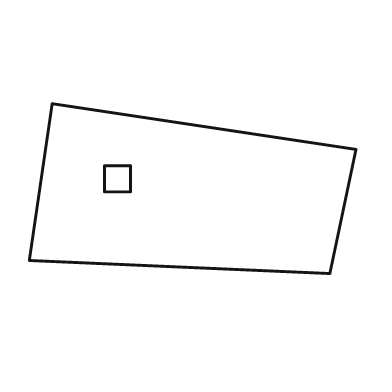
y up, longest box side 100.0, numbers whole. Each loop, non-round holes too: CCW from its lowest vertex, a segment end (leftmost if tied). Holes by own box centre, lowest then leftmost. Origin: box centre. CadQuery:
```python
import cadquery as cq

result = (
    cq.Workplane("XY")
    .moveTo(42.0, -26.0)
    .lineTo(50.0, 12.0)
    .lineTo(-43.0, 26.0)
    .lineTo(-50.0, -22.0)
    .close()
    .moveTo(-27.0, -1.0)
    .lineTo(-19.0, -1.0)
    .lineTo(-19.0, 7.0)
    .lineTo(-27.0, 7.0)
    .close()
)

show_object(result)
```